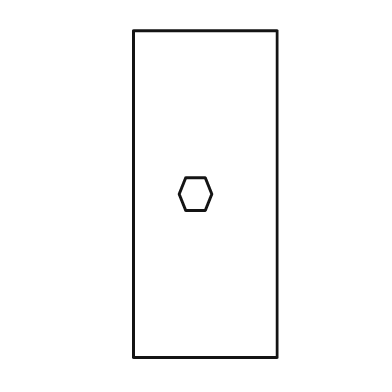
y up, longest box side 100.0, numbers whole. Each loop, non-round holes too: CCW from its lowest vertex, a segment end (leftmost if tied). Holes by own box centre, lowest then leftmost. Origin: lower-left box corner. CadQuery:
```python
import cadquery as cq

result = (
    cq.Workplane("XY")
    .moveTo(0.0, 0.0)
    .lineTo(44.0, 0.0)
    .lineTo(44.0, 100.0)
    .lineTo(0.0, 100.0)
    .close()
    .moveTo(16.0, 45.0)
    .lineTo(22.0, 45.0)
    .lineTo(24.0, 50.0)
    .lineTo(22.0, 55.0)
    .lineTo(16.0, 55.0)
    .lineTo(14.0, 50.0)
    .close()
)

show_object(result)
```